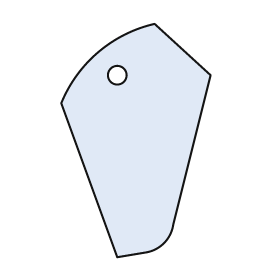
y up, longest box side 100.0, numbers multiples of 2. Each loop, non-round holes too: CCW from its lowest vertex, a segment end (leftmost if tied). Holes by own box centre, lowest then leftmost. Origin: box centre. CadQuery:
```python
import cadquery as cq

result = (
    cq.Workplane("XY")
    .moveTo(-8.0, -50.0)
    .lineTo(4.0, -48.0)
    .threePointArc((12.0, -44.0), (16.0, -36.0))
    .lineTo(32.0, 28.0)
    .lineTo(8.0, 50.0)
    .threePointArc((-16.0, 38.0), (-32.0, 16.0))
    .close()
    .moveTo(-8.0, 28.0)
    .circle(4.0)
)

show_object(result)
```